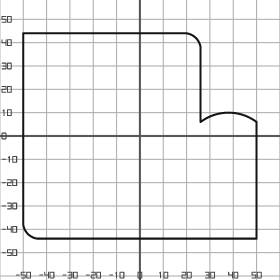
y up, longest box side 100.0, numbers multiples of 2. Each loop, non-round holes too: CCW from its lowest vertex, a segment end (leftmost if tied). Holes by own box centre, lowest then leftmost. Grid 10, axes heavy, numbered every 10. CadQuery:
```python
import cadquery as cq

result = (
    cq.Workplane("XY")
    .moveTo(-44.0, -44.0)
    .lineTo(50.0, -44.0)
    .lineTo(50.0, 6.0)
    .threePointArc((38.0, 10.0), (26.0, 6.0))
    .lineTo(26.0, 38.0)
    .threePointArc((24.0, 42.0), (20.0, 44.0))
    .lineTo(-50.0, 44.0)
    .lineTo(-50.0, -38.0)
    .threePointArc((-48.0, -42.0), (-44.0, -44.0))
    .close()
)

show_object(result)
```